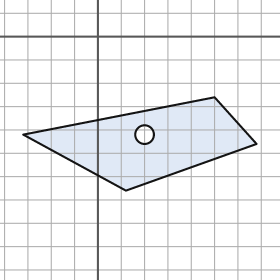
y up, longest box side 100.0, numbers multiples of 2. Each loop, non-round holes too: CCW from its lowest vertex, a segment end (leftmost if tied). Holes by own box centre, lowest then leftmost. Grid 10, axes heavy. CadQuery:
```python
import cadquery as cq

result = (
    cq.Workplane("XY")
    .moveTo(12.0, -66.0)
    .lineTo(68.0, -46.0)
    .lineTo(50.0, -26.0)
    .lineTo(-32.0, -42.0)
    .close()
    .moveTo(20.0, -42.0)
    .circle(4.0)
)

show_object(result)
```